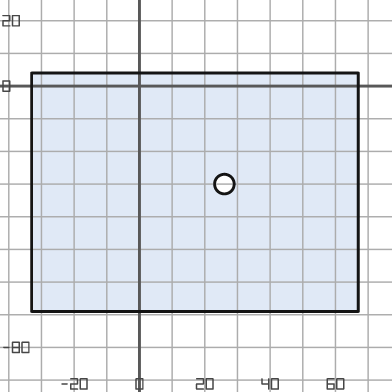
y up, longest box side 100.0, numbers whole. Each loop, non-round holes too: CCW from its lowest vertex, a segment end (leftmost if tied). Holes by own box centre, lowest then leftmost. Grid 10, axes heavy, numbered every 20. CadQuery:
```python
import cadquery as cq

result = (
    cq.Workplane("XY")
    .moveTo(-33.0, -69.0)
    .lineTo(67.0, -69.0)
    .lineTo(67.0, 4.0)
    .lineTo(-33.0, 4.0)
    .close()
    .moveTo(26.0, -30.0)
    .circle(3.0)
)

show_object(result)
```